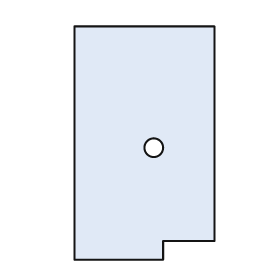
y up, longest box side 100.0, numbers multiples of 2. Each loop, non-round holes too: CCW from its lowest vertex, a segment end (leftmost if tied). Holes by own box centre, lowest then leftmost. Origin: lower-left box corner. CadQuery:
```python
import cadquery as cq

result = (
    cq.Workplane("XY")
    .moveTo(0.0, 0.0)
    .lineTo(38.0, 0.0)
    .lineTo(38.0, 8.0)
    .lineTo(60.0, 8.0)
    .lineTo(60.0, 100.0)
    .lineTo(0.0, 100.0)
    .close()
    .moveTo(34.0, 48.0)
    .circle(4.0)
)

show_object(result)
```